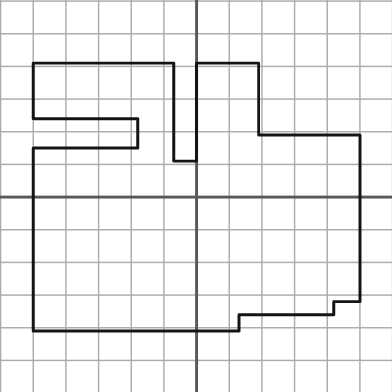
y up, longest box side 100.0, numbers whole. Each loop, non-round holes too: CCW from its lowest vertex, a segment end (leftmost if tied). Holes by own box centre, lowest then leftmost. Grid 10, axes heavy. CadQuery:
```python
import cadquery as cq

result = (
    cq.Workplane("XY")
    .moveTo(-50.0, -41.0)
    .lineTo(13.0, -41.0)
    .lineTo(13.0, -36.0)
    .lineTo(42.0, -36.0)
    .lineTo(42.0, -32.0)
    .lineTo(50.0, -32.0)
    .lineTo(50.0, 19.0)
    .lineTo(19.0, 19.0)
    .lineTo(19.0, 41.0)
    .lineTo(0.0, 41.0)
    .lineTo(0.0, 11.0)
    .lineTo(-7.0, 11.0)
    .lineTo(-7.0, 41.0)
    .lineTo(-50.0, 41.0)
    .lineTo(-50.0, 24.0)
    .lineTo(-18.0, 24.0)
    .lineTo(-18.0, 15.0)
    .lineTo(-50.0, 15.0)
    .close()
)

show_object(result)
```